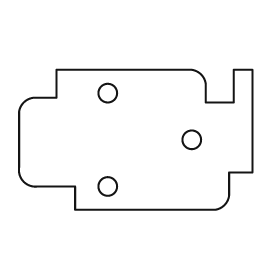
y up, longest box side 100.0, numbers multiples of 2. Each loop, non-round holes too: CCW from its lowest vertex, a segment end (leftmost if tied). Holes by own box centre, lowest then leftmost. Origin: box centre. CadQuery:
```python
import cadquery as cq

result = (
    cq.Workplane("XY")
    .moveTo(-26.0, -30.0)
    .lineTo(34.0, -30.0)
    .threePointArc((38.0, -28.0), (40.0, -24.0))
    .lineTo(40.0, -14.0)
    .lineTo(50.0, -14.0)
    .lineTo(50.0, 30.0)
    .lineTo(42.0, 30.0)
    .lineTo(42.0, 16.0)
    .lineTo(30.0, 16.0)
    .lineTo(30.0, 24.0)
    .threePointArc((28.0, 28.0), (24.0, 30.0))
    .lineTo(-34.0, 30.0)
    .lineTo(-34.0, 18.0)
    .lineTo(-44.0, 18.0)
    .threePointArc((-48.0, 16.0), (-50.0, 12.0))
    .lineTo(-50.0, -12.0)
    .threePointArc((-48.0, -18.0), (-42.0, -20.0))
    .lineTo(-26.0, -20.0)
    .close()
    .moveTo(-12.0, -20.0)
    .circle(4.0)
    .moveTo(24.0, 0.0)
    .circle(4.0)
    .moveTo(-12.0, 20.0)
    .circle(4.0)
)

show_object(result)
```